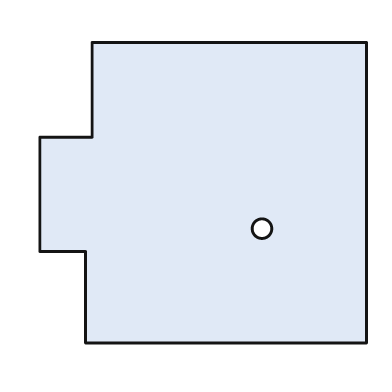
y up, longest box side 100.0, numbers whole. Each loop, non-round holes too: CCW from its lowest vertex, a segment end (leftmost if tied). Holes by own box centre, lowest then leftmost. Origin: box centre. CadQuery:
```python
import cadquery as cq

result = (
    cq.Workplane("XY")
    .moveTo(-36.0, -46.0)
    .lineTo(50.0, -46.0)
    .lineTo(50.0, 46.0)
    .lineTo(-34.0, 46.0)
    .lineTo(-34.0, 17.0)
    .lineTo(-50.0, 17.0)
    .lineTo(-50.0, -18.0)
    .lineTo(-36.0, -18.0)
    .close()
    .moveTo(18.0, -11.0)
    .circle(3.0)
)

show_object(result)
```